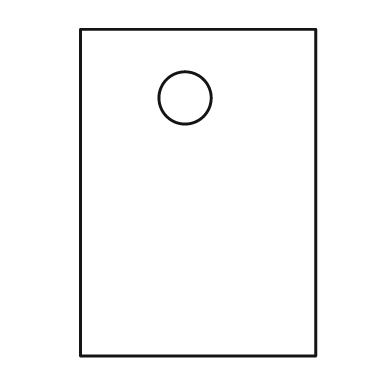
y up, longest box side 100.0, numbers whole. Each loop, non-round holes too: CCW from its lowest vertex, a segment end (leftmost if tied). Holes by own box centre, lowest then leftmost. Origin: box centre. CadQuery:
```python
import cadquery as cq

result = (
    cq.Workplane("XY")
    .moveTo(-36.0, -50.0)
    .lineTo(36.0, -50.0)
    .lineTo(36.0, 50.0)
    .lineTo(-36.0, 50.0)
    .close()
    .moveTo(-4.0, 29.0)
    .circle(8.0)
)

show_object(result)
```